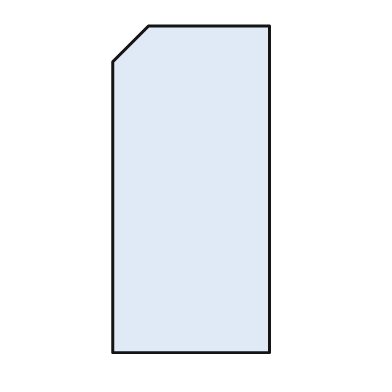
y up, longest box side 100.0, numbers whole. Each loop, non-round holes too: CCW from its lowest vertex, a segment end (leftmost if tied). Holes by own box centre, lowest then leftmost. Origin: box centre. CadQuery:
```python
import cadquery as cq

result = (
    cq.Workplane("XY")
    .moveTo(-24.0, -50.0)
    .lineTo(24.0, -50.0)
    .lineTo(24.0, 50.0)
    .lineTo(-13.0, 50.0)
    .lineTo(-24.0, 39.0)
    .close()
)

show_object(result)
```